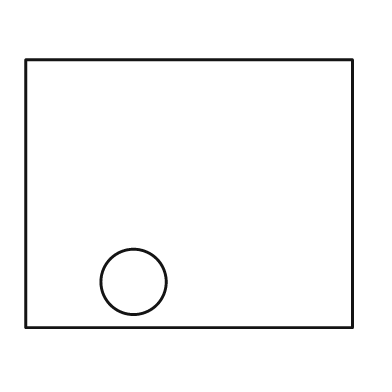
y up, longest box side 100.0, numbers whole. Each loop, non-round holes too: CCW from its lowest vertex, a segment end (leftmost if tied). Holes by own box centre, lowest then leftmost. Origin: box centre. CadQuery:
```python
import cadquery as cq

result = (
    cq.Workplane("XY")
    .moveTo(-50.0, -41.0)
    .lineTo(50.0, -41.0)
    .lineTo(50.0, 41.0)
    .lineTo(-50.0, 41.0)
    .close()
    .moveTo(-17.0, -27.0)
    .circle(10.0)
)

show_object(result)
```